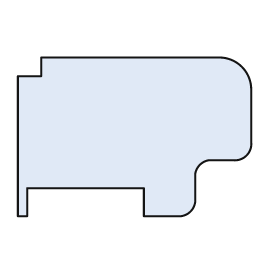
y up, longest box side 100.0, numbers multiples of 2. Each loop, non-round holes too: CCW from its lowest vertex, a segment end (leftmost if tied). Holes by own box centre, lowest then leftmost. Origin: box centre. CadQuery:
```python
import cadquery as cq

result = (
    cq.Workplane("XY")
    .moveTo(-50.0, -34.0)
    .lineTo(-46.0, -34.0)
    .lineTo(-46.0, -22.0)
    .lineTo(4.0, -22.0)
    .lineTo(4.0, -34.0)
    .lineTo(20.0, -34.0)
    .threePointArc((24.0, -32.0), (26.0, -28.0))
    .lineTo(26.0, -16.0)
    .threePointArc((28.0, -12.0), (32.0, -10.0))
    .lineTo(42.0, -10.0)
    .threePointArc((48.0, -8.0), (50.0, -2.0))
    .lineTo(50.0, 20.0)
    .threePointArc((46.0, 30.0), (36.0, 34.0))
    .lineTo(-40.0, 34.0)
    .lineTo(-40.0, 26.0)
    .lineTo(-50.0, 26.0)
    .close()
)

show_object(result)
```